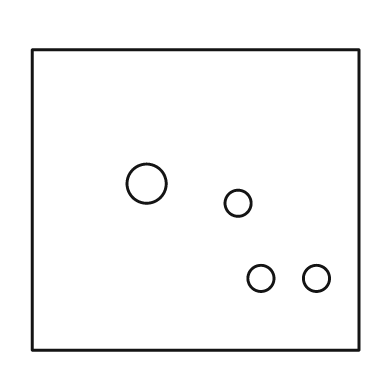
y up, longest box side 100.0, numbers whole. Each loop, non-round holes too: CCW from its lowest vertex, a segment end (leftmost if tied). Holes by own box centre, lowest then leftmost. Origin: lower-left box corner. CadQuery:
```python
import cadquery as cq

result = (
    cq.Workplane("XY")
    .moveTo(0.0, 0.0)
    .lineTo(100.0, 0.0)
    .lineTo(100.0, 92.0)
    .lineTo(0.0, 92.0)
    .close()
    .moveTo(70.0, 22.0)
    .circle(4.0)
    .moveTo(87.0, 22.0)
    .circle(4.0)
    .moveTo(63.0, 45.0)
    .circle(4.0)
    .moveTo(35.0, 51.0)
    .circle(6.0)
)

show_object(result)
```